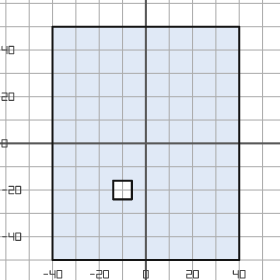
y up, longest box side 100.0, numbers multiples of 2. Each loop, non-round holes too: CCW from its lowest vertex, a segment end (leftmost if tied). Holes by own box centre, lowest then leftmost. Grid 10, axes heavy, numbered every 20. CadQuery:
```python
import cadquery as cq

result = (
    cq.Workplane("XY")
    .moveTo(-40.0, -50.0)
    .lineTo(40.0, -50.0)
    .lineTo(40.0, 50.0)
    .lineTo(-40.0, 50.0)
    .close()
    .moveTo(-14.0, -24.0)
    .lineTo(-6.0, -24.0)
    .lineTo(-6.0, -16.0)
    .lineTo(-14.0, -16.0)
    .close()
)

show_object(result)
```